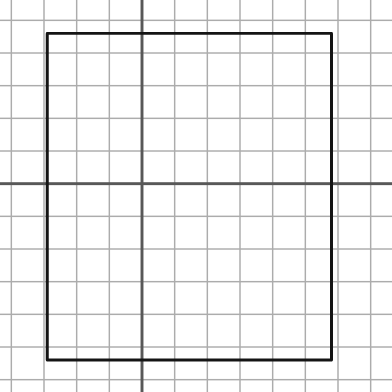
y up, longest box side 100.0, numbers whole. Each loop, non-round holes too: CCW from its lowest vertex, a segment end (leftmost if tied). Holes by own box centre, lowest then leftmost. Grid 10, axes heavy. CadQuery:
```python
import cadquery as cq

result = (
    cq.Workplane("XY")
    .moveTo(-29.0, -54.0)
    .lineTo(58.0, -54.0)
    .lineTo(58.0, 46.0)
    .lineTo(-29.0, 46.0)
    .close()
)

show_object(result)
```